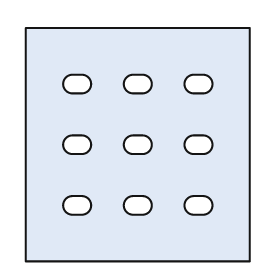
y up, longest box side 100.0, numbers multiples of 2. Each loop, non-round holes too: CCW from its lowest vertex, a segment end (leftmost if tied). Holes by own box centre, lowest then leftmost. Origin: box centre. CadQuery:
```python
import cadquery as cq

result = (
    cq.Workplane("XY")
    .moveTo(-48.0, -50.0)
    .lineTo(48.0, -50.0)
    .lineTo(48.0, 50.0)
    .lineTo(-48.0, 50.0)
    .close()
    .moveTo(-28.0, -30.0)
    .lineTo(-24.0, -30.0)
    .threePointArc((-20.0, -26.0), (-24.0, -22.0))
    .lineTo(-28.0, -22.0)
    .threePointArc((-32.0, -26.0), (-28.0, -30.0))
    .close()
    .moveTo(-2.0, -30.0)
    .lineTo(2.0, -30.0)
    .threePointArc((6.0, -26.0), (2.0, -22.0))
    .lineTo(-2.0, -22.0)
    .threePointArc((-6.0, -26.0), (-2.0, -30.0))
    .close()
    .moveTo(24.0, -30.0)
    .lineTo(28.0, -30.0)
    .threePointArc((32.0, -26.0), (28.0, -22.0))
    .lineTo(24.0, -22.0)
    .threePointArc((20.0, -26.0), (24.0, -30.0))
    .close()
    .moveTo(-28.0, -4.0)
    .lineTo(-24.0, -4.0)
    .threePointArc((-20.0, 0.0), (-24.0, 4.0))
    .lineTo(-28.0, 4.0)
    .threePointArc((-32.0, 0.0), (-28.0, -4.0))
    .close()
    .moveTo(-2.0, -4.0)
    .lineTo(2.0, -4.0)
    .threePointArc((6.0, 0.0), (2.0, 4.0))
    .lineTo(-2.0, 4.0)
    .threePointArc((-6.0, 0.0), (-2.0, -4.0))
    .close()
    .moveTo(24.0, -4.0)
    .lineTo(28.0, -4.0)
    .threePointArc((32.0, 0.0), (28.0, 4.0))
    .lineTo(24.0, 4.0)
    .threePointArc((20.0, 0.0), (24.0, -4.0))
    .close()
    .moveTo(-28.0, 22.0)
    .lineTo(-24.0, 22.0)
    .threePointArc((-20.0, 26.0), (-24.0, 30.0))
    .lineTo(-28.0, 30.0)
    .threePointArc((-32.0, 26.0), (-28.0, 22.0))
    .close()
    .moveTo(-2.0, 22.0)
    .lineTo(2.0, 22.0)
    .threePointArc((6.0, 26.0), (2.0, 30.0))
    .lineTo(-2.0, 30.0)
    .threePointArc((-6.0, 26.0), (-2.0, 22.0))
    .close()
    .moveTo(24.0, 22.0)
    .lineTo(28.0, 22.0)
    .threePointArc((32.0, 26.0), (28.0, 30.0))
    .lineTo(24.0, 30.0)
    .threePointArc((20.0, 26.0), (24.0, 22.0))
    .close()
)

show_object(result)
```